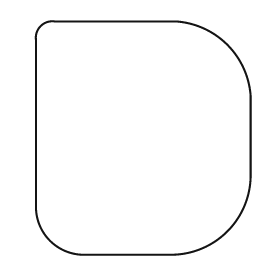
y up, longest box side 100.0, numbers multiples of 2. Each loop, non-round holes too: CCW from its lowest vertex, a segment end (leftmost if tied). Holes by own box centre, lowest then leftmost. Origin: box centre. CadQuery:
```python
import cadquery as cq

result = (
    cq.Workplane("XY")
    .moveTo(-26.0, -50.0)
    .lineTo(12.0, -50.0)
    .threePointArc((36.0, -40.0), (46.0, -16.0))
    .lineTo(46.0, 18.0)
    .threePointArc((36.0, 40.0), (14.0, 50.0))
    .lineTo(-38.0, 50.0)
    .threePointArc((-44.0, 48.0), (-46.0, 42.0))
    .lineTo(-46.0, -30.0)
    .threePointArc((-40.0, -44.0), (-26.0, -50.0))
    .close()
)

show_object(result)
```